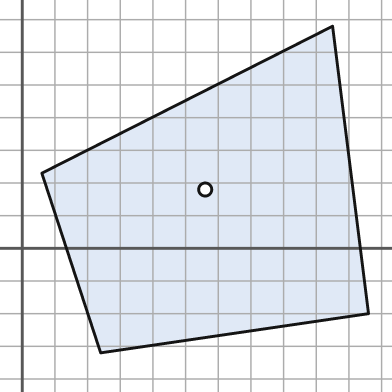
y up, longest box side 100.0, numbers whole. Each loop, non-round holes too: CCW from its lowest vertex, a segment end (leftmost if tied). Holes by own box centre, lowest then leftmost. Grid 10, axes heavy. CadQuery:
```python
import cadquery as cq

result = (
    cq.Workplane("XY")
    .moveTo(24.0, -32.0)
    .lineTo(106.0, -20.0)
    .lineTo(95.0, 68.0)
    .lineTo(6.0, 23.0)
    .close()
    .moveTo(56.0, 18.0)
    .circle(2.0)
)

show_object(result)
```